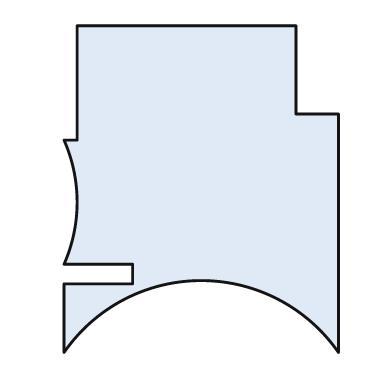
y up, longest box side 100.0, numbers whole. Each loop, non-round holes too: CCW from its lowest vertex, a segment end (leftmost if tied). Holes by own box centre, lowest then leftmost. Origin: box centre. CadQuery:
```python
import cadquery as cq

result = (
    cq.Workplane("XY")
    .moveTo(-42.0, -50.0)
    .threePointArc((0.0, -28.0), (42.0, -50.0))
    .lineTo(42.0, 23.0)
    .lineTo(29.0, 23.0)
    .lineTo(29.0, 50.0)
    .lineTo(-38.0, 50.0)
    .lineTo(-38.0, 15.0)
    .lineTo(-42.0, 15.0)
    .threePointArc((-38.0, -4.0), (-42.0, -23.0))
    .lineTo(-21.0, -23.0)
    .lineTo(-21.0, -29.0)
    .lineTo(-42.0, -29.0)
    .close()
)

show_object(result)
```